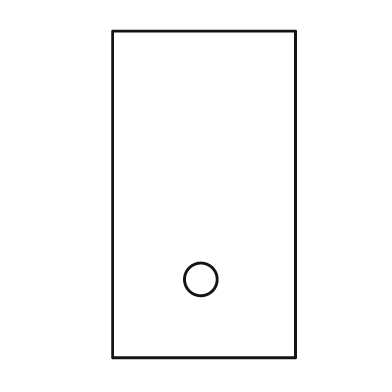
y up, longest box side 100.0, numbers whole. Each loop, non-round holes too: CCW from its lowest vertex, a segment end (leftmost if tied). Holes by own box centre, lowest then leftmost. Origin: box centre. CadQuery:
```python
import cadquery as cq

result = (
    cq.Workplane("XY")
    .moveTo(-28.0, -50.0)
    .lineTo(28.0, -50.0)
    .lineTo(28.0, 50.0)
    .lineTo(-28.0, 50.0)
    .close()
    .moveTo(-1.0, -26.0)
    .circle(5.0)
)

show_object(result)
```